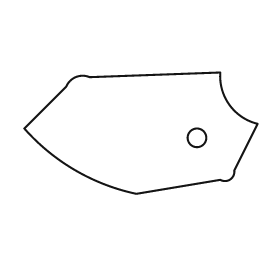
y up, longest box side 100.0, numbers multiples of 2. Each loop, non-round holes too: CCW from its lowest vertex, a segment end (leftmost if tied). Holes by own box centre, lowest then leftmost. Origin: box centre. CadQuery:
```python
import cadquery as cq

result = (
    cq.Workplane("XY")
    .moveTo(-2.0, -26.0)
    .lineTo(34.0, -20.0)
    .threePointArc((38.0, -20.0), (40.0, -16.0))
    .lineTo(50.0, 4.0)
    .threePointArc((38.0, 12.0), (34.0, 26.0))
    .lineTo(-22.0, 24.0)
    .threePointArc((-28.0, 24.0), (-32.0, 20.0))
    .lineTo(-50.0, 2.0)
    .threePointArc((-28.0, -16.0), (-2.0, -26.0))
    .close()
    .moveTo(24.0, -2.0)
    .circle(4.0)
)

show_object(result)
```